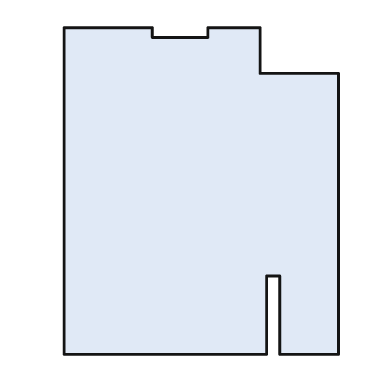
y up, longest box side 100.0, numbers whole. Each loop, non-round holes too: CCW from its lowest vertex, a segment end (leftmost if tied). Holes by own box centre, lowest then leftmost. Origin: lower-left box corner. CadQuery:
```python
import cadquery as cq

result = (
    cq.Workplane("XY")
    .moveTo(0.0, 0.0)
    .lineTo(62.0, 0.0)
    .lineTo(62.0, 24.0)
    .lineTo(66.0, 24.0)
    .lineTo(66.0, 0.0)
    .lineTo(84.0, 0.0)
    .lineTo(84.0, 86.0)
    .lineTo(60.0, 86.0)
    .lineTo(60.0, 100.0)
    .lineTo(44.0, 100.0)
    .lineTo(44.0, 97.0)
    .lineTo(27.0, 97.0)
    .lineTo(27.0, 100.0)
    .lineTo(0.0, 100.0)
    .close()
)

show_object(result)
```